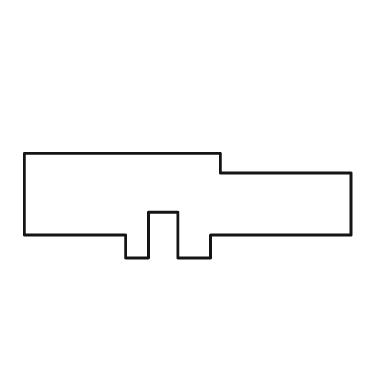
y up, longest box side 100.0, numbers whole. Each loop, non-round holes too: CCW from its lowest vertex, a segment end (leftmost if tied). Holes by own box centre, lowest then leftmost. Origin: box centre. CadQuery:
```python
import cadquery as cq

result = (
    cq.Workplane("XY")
    .moveTo(-19.0, -16.0)
    .lineTo(-12.0, -16.0)
    .lineTo(-12.0, -2.0)
    .lineTo(-3.0, -2.0)
    .lineTo(-3.0, -16.0)
    .lineTo(7.0, -16.0)
    .lineTo(7.0, -9.0)
    .lineTo(50.0, -9.0)
    .lineTo(50.0, 10.0)
    .lineTo(10.0, 10.0)
    .lineTo(10.0, 16.0)
    .lineTo(-50.0, 16.0)
    .lineTo(-50.0, -9.0)
    .lineTo(-19.0, -9.0)
    .close()
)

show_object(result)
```